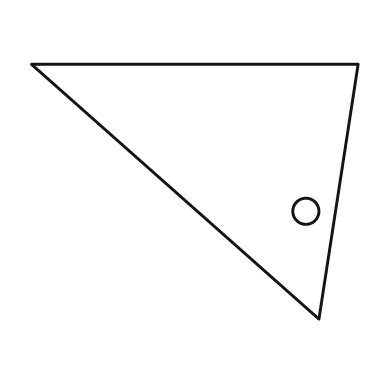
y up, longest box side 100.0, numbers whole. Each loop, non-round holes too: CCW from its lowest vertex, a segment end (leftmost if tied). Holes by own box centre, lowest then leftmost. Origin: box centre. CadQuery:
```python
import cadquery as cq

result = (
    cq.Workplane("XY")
    .moveTo(38.0, -39.0)
    .lineTo(50.0, 39.0)
    .lineTo(-50.0, 39.0)
    .close()
    .moveTo(34.0, -6.0)
    .circle(4.0)
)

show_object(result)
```